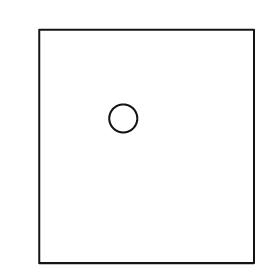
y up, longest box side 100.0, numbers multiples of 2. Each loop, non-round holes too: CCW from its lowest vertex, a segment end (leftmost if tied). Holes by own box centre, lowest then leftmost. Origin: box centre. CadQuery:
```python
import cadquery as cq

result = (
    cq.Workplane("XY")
    .moveTo(-46.0, -50.0)
    .lineTo(46.0, -50.0)
    .lineTo(46.0, 50.0)
    .lineTo(-46.0, 50.0)
    .close()
    .moveTo(-10.0, 12.0)
    .circle(6.0)
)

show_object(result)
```